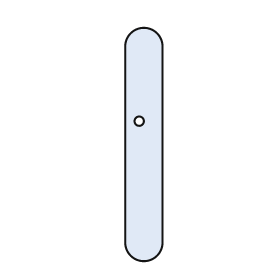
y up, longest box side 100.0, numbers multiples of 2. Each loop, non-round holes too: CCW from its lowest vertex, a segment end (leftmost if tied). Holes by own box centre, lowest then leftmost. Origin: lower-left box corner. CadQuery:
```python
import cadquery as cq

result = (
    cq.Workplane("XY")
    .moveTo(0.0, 8.0)
    .threePointArc((8.0, 0.0), (16.0, 8.0))
    .lineTo(16.0, 92.0)
    .threePointArc((8.0, 100.0), (0.0, 92.0))
    .close()
    .moveTo(6.0, 60.0)
    .circle(2.0)
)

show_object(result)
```